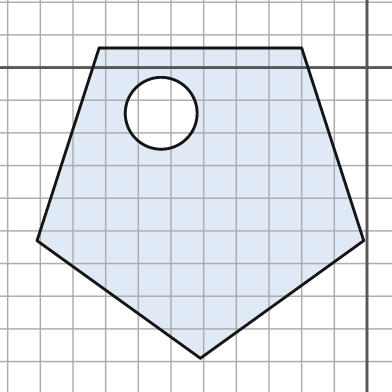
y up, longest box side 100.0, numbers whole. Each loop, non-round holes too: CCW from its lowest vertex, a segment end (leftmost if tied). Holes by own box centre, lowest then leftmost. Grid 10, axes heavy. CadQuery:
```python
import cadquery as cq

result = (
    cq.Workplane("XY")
    .moveTo(-51.0, -89.0)
    .lineTo(-1.0, -53.0)
    .lineTo(-20.0, 6.0)
    .lineTo(-82.0, 6.0)
    .lineTo(-101.0, -53.0)
    .close()
    .moveTo(-63.0, -14.0)
    .circle(11.0)
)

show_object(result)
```